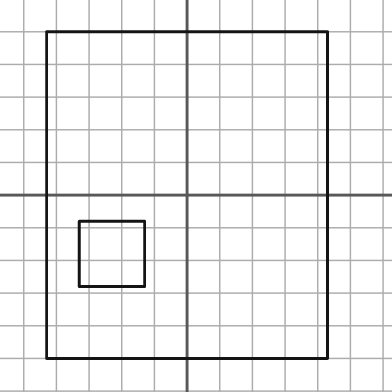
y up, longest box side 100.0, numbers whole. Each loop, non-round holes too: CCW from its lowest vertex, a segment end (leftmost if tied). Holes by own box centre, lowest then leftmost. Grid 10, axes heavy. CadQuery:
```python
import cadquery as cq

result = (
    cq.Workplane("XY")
    .moveTo(-43.0, -50.0)
    .lineTo(43.0, -50.0)
    .lineTo(43.0, 50.0)
    .lineTo(-43.0, 50.0)
    .close()
    .moveTo(-33.0, -28.0)
    .lineTo(-13.0, -28.0)
    .lineTo(-13.0, -8.0)
    .lineTo(-33.0, -8.0)
    .close()
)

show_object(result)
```